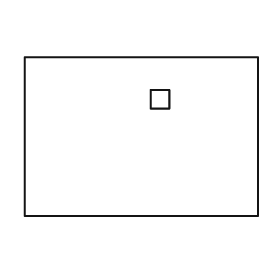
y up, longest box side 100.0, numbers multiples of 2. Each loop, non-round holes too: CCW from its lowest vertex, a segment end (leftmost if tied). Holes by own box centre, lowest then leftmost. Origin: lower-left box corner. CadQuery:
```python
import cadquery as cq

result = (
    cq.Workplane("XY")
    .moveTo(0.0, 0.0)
    .lineTo(100.0, 0.0)
    .lineTo(100.0, 68.0)
    .lineTo(0.0, 68.0)
    .close()
    .moveTo(54.0, 46.0)
    .lineTo(62.0, 46.0)
    .lineTo(62.0, 54.0)
    .lineTo(54.0, 54.0)
    .close()
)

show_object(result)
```